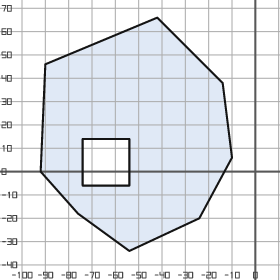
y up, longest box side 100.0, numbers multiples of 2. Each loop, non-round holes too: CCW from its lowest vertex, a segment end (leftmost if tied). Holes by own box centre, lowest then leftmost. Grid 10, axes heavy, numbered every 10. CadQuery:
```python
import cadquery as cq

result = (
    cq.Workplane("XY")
    .moveTo(-54.0, -34.0)
    .lineTo(-24.0, -20.0)
    .lineTo(-10.0, 6.0)
    .lineTo(-14.0, 38.0)
    .lineTo(-42.0, 66.0)
    .lineTo(-90.0, 46.0)
    .lineTo(-92.0, 0.0)
    .lineTo(-76.0, -18.0)
    .close()
    .moveTo(-74.0, -6.0)
    .lineTo(-54.0, -6.0)
    .lineTo(-54.0, 14.0)
    .lineTo(-74.0, 14.0)
    .close()
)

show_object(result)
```